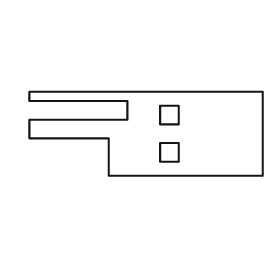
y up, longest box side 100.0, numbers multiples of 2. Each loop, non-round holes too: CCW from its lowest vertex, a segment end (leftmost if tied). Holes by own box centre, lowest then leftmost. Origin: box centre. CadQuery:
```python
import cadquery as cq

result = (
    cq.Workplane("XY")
    .moveTo(-16.0, -18.0)
    .lineTo(50.0, -18.0)
    .lineTo(50.0, 18.0)
    .lineTo(-50.0, 18.0)
    .lineTo(-50.0, 14.0)
    .lineTo(-8.0, 14.0)
    .lineTo(-8.0, 6.0)
    .lineTo(-50.0, 6.0)
    .lineTo(-50.0, -2.0)
    .lineTo(-16.0, -2.0)
    .close()
    .moveTo(6.0, -12.0)
    .lineTo(14.0, -12.0)
    .lineTo(14.0, -4.0)
    .lineTo(6.0, -4.0)
    .close()
    .moveTo(6.0, 4.0)
    .lineTo(14.0, 4.0)
    .lineTo(14.0, 12.0)
    .lineTo(6.0, 12.0)
    .close()
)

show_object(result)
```